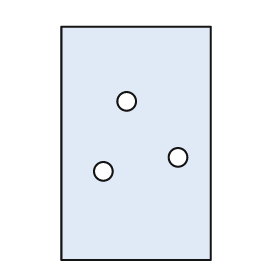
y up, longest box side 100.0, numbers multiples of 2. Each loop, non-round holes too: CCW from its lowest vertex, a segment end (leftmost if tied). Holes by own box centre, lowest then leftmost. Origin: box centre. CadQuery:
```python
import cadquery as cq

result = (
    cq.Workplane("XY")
    .moveTo(-32.0, -50.0)
    .lineTo(32.0, -50.0)
    .lineTo(32.0, 50.0)
    .lineTo(-32.0, 50.0)
    .close()
    .moveTo(-14.0, -12.0)
    .circle(4.0)
    .moveTo(18.0, -6.0)
    .circle(4.0)
    .moveTo(-4.0, 18.0)
    .circle(4.0)
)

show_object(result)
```